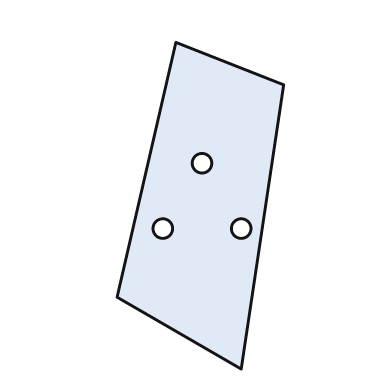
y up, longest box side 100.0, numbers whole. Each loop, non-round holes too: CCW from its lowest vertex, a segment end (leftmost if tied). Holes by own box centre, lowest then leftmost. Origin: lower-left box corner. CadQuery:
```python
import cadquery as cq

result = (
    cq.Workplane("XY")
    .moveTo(38.0, 0.0)
    .lineTo(51.0, 87.0)
    .lineTo(18.0, 100.0)
    .lineTo(0.0, 22.0)
    .close()
    .moveTo(14.0, 43.0)
    .circle(3.0)
    .moveTo(38.0, 43.0)
    .circle(3.0)
    .moveTo(26.0, 63.0)
    .circle(3.0)
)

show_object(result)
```